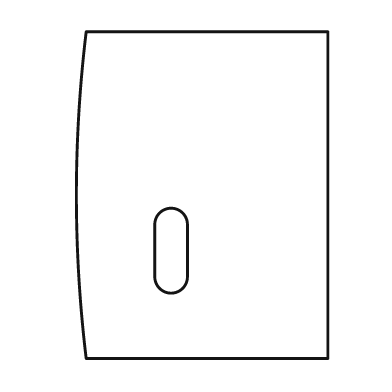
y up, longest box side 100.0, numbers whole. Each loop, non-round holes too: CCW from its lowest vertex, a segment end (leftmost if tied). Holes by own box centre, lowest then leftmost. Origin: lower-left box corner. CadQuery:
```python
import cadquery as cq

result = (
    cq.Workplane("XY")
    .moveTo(3.0, 0.0)
    .lineTo(77.0, 0.0)
    .lineTo(77.0, 100.0)
    .lineTo(3.0, 100.0)
    .threePointArc((0.0, 50.0), (3.0, 0.0))
    .close()
    .moveTo(24.0, 25.0)
    .threePointArc((29.0, 20.0), (34.0, 25.0))
    .lineTo(34.0, 41.0)
    .threePointArc((29.0, 46.0), (24.0, 41.0))
    .close()
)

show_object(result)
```